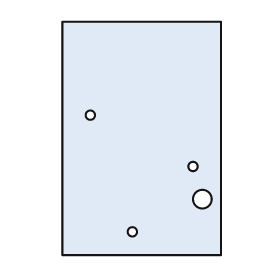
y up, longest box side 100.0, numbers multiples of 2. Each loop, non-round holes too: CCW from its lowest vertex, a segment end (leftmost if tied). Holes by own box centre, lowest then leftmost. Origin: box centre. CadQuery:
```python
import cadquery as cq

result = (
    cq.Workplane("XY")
    .moveTo(-34.0, -50.0)
    .lineTo(34.0, -50.0)
    .lineTo(34.0, 50.0)
    .lineTo(-34.0, 50.0)
    .close()
    .moveTo(-4.0, -40.0)
    .circle(2.0)
    .moveTo(26.0, -26.0)
    .circle(4.0)
    .moveTo(22.0, -12.0)
    .circle(2.0)
    .moveTo(-22.0, 10.0)
    .circle(2.0)
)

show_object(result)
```